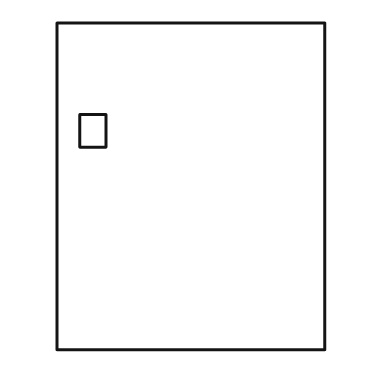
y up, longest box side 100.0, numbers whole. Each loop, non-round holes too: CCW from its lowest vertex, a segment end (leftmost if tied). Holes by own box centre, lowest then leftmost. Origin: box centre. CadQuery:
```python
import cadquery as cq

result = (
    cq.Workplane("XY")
    .moveTo(-41.0, -50.0)
    .lineTo(41.0, -50.0)
    .lineTo(41.0, 50.0)
    .lineTo(-41.0, 50.0)
    .close()
    .moveTo(-34.0, 12.0)
    .lineTo(-26.0, 12.0)
    .lineTo(-26.0, 22.0)
    .lineTo(-34.0, 22.0)
    .close()
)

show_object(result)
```